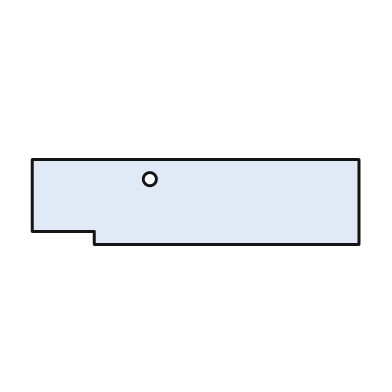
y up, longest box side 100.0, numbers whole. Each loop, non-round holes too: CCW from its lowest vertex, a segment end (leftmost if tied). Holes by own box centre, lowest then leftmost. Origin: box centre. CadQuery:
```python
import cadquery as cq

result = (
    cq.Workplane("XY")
    .moveTo(-31.0, -13.0)
    .lineTo(50.0, -13.0)
    .lineTo(50.0, 13.0)
    .lineTo(-50.0, 13.0)
    .lineTo(-50.0, -9.0)
    .lineTo(-31.0, -9.0)
    .close()
    .moveTo(-14.0, 7.0)
    .circle(2.0)
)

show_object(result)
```